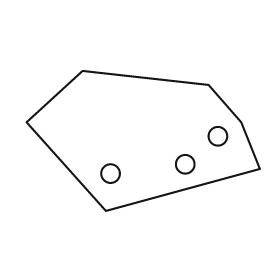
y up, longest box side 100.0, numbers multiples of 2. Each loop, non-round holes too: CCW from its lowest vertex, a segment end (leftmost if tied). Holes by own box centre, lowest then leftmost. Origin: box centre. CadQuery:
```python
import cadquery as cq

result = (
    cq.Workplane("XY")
    .moveTo(-16.0, -30.0)
    .lineTo(50.0, -12.0)
    .lineTo(42.0, 8.0)
    .lineTo(28.0, 24.0)
    .lineTo(-26.0, 30.0)
    .lineTo(-50.0, 8.0)
    .close()
    .moveTo(-14.0, -14.0)
    .circle(4.0)
    .moveTo(18.0, -10.0)
    .circle(4.0)
    .moveTo(32.0, 2.0)
    .circle(4.0)
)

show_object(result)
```